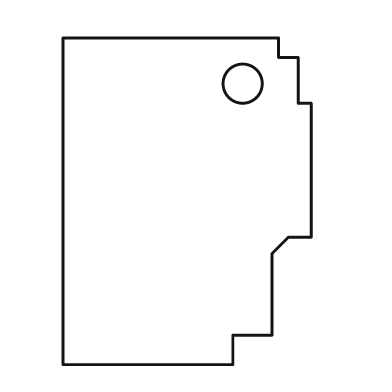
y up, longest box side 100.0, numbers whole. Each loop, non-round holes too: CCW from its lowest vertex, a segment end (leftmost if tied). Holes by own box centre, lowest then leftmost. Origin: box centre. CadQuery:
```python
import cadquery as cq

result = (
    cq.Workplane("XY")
    .moveTo(-38.0, -50.0)
    .lineTo(14.0, -50.0)
    .lineTo(14.0, -41.0)
    .lineTo(26.0, -41.0)
    .lineTo(26.0, -16.0)
    .lineTo(31.0, -11.0)
    .lineTo(38.0, -11.0)
    .lineTo(38.0, 30.0)
    .lineTo(34.0, 30.0)
    .lineTo(34.0, 44.0)
    .lineTo(28.0, 44.0)
    .lineTo(28.0, 50.0)
    .lineTo(-38.0, 50.0)
    .close()
    .moveTo(17.0, 36.0)
    .circle(6.0)
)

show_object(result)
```